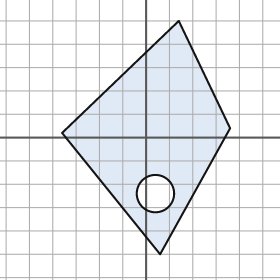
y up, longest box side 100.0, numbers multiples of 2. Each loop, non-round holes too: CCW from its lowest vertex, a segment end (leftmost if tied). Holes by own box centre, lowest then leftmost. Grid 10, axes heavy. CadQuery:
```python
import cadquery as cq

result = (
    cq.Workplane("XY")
    .moveTo(6.0, -50.0)
    .lineTo(36.0, 4.0)
    .lineTo(14.0, 50.0)
    .lineTo(-36.0, 2.0)
    .close()
    .moveTo(4.0, -24.0)
    .circle(8.0)
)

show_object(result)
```